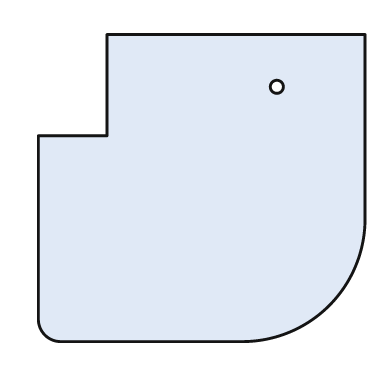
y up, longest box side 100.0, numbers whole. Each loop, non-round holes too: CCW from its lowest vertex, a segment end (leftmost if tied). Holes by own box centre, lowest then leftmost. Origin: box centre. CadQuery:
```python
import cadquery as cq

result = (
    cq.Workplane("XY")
    .moveTo(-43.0, -47.0)
    .lineTo(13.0, -47.0)
    .threePointArc((39.0, -36.0), (50.0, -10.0))
    .lineTo(50.0, 47.0)
    .lineTo(-29.0, 47.0)
    .lineTo(-29.0, 16.0)
    .lineTo(-50.0, 16.0)
    .lineTo(-50.0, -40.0)
    .threePointArc((-48.0, -45.0), (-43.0, -47.0))
    .close()
    .moveTo(23.0, 31.0)
    .circle(2.0)
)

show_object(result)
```